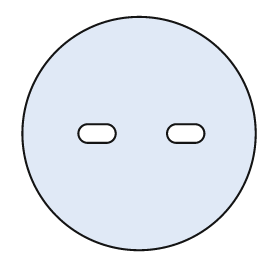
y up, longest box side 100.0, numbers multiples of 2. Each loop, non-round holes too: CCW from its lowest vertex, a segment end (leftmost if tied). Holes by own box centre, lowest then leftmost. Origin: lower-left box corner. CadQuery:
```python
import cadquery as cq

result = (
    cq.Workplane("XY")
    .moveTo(50.0, 50.0)
    .circle(50.0)
    .moveTo(28.0, 46.0)
    .lineTo(36.0, 46.0)
    .threePointArc((40.0, 50.0), (36.0, 54.0))
    .lineTo(28.0, 54.0)
    .threePointArc((24.0, 50.0), (28.0, 46.0))
    .close()
    .moveTo(66.0, 46.0)
    .lineTo(74.0, 46.0)
    .threePointArc((78.0, 50.0), (74.0, 54.0))
    .lineTo(66.0, 54.0)
    .threePointArc((62.0, 50.0), (66.0, 46.0))
    .close()
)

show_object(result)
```